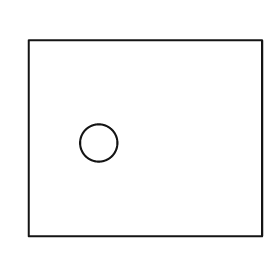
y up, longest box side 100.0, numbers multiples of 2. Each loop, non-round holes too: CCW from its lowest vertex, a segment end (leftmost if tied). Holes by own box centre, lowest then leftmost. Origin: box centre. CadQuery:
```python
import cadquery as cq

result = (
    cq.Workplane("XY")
    .moveTo(-50.0, -42.0)
    .lineTo(50.0, -42.0)
    .lineTo(50.0, 42.0)
    .lineTo(-50.0, 42.0)
    .close()
    .moveTo(-20.0, -2.0)
    .circle(8.0)
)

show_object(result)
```